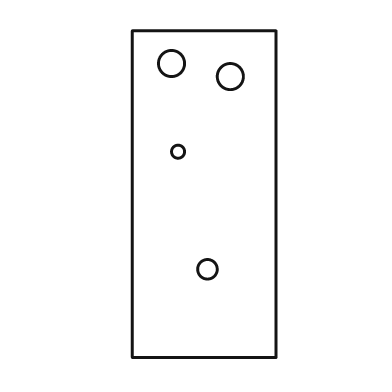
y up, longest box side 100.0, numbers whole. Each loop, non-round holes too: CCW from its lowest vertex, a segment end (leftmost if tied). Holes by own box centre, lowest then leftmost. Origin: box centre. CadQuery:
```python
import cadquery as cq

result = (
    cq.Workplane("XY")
    .moveTo(-22.0, -50.0)
    .lineTo(22.0, -50.0)
    .lineTo(22.0, 50.0)
    .lineTo(-22.0, 50.0)
    .close()
    .moveTo(1.0, -23.0)
    .circle(3.0)
    .moveTo(-8.0, 13.0)
    .circle(2.0)
    .moveTo(8.0, 36.0)
    .circle(4.0)
    .moveTo(-10.0, 40.0)
    .circle(4.0)
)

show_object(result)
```